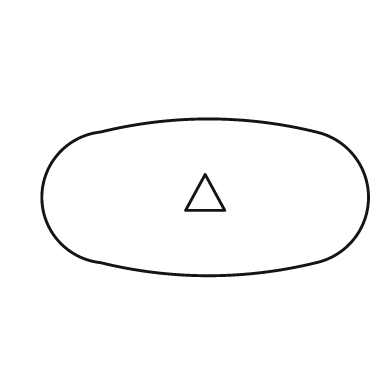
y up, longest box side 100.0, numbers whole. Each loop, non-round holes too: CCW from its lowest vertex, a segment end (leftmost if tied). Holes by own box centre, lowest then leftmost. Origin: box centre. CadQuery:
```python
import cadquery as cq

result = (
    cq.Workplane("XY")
    .moveTo(-32.0, -20.0)
    .threePointArc((1.0, -24.0), (34.0, -20.0))
    .threePointArc((50.0, 0.0), (34.0, 20.0))
    .threePointArc((1.0, 24.0), (-32.0, 20.0))
    .threePointArc((-50.0, 0.0), (-32.0, -20.0))
    .close()
    .moveTo(-6.0, -4.0)
    .lineTo(6.0, -4.0)
    .lineTo(0.0, 7.0)
    .close()
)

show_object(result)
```